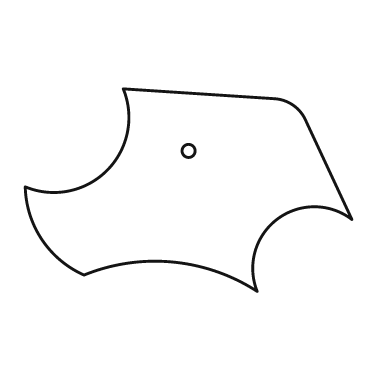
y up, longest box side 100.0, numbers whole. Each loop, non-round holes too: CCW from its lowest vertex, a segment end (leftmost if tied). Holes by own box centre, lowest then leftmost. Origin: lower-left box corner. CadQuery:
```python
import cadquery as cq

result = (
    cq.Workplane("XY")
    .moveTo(71.0, 0.0)
    .threePointArc((77.0, 22.0), (100.0, 22.0))
    .lineTo(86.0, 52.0)
    .threePointArc((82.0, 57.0), (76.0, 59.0))
    .lineTo(30.0, 62.0)
    .threePointArc((25.0, 37.0), (0.0, 32.0))
    .threePointArc((5.0, 16.0), (18.0, 5.0))
    .threePointArc((45.0, 9.0), (71.0, 0.0))
    .close()
    .moveTo(50.0, 43.0)
    .circle(2.0)
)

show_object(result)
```